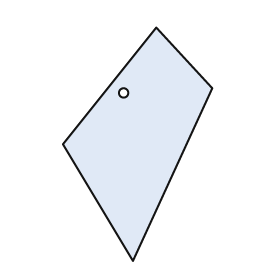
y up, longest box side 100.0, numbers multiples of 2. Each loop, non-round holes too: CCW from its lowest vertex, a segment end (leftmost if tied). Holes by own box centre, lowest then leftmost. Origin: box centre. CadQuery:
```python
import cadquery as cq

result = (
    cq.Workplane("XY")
    .moveTo(-2.0, -50.0)
    .lineTo(32.0, 24.0)
    .lineTo(8.0, 50.0)
    .lineTo(-32.0, 0.0)
    .close()
    .moveTo(-6.0, 22.0)
    .circle(2.0)
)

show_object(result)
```